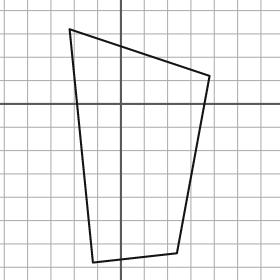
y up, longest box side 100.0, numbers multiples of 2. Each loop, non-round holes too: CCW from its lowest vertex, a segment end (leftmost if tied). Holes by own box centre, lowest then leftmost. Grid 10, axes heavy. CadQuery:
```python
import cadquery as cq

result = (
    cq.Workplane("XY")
    .moveTo(-12.0, -68.0)
    .lineTo(24.0, -64.0)
    .lineTo(38.0, 12.0)
    .lineTo(-22.0, 32.0)
    .close()
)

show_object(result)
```